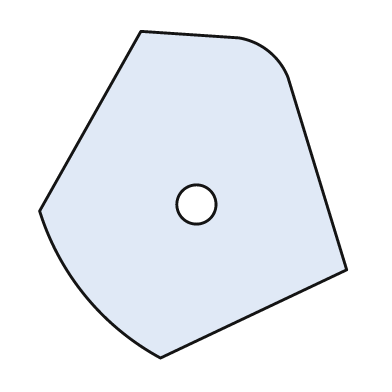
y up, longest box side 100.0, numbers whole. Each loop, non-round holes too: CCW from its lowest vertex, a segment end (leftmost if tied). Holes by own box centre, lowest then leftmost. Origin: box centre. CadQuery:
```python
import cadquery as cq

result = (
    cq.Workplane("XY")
    .moveTo(-10.0, -50.0)
    .lineTo(47.0, -23.0)
    .lineTo(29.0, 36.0)
    .threePointArc((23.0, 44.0), (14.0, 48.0))
    .lineTo(-16.0, 50.0)
    .lineTo(-47.0, -5.0)
    .threePointArc((-33.0, -31.0), (-10.0, -50.0))
    .close()
    .moveTo(1.0, -3.0)
    .circle(6.0)
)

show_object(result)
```